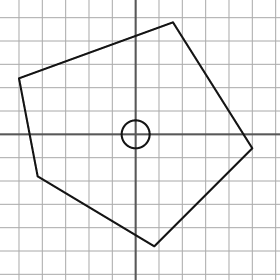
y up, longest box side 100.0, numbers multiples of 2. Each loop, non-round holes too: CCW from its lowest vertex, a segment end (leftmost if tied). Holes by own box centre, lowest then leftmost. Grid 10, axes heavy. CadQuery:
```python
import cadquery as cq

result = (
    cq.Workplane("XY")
    .moveTo(8.0, -48.0)
    .lineTo(50.0, -6.0)
    .lineTo(16.0, 48.0)
    .lineTo(-50.0, 24.0)
    .lineTo(-42.0, -18.0)
    .close()
    .moveTo(0.0, 0.0)
    .circle(6.0)
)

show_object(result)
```